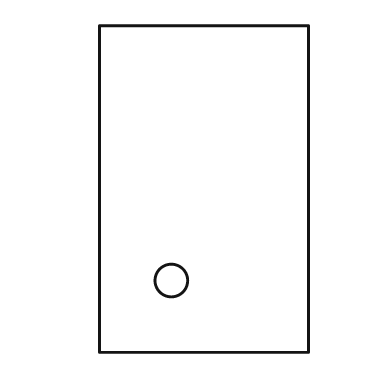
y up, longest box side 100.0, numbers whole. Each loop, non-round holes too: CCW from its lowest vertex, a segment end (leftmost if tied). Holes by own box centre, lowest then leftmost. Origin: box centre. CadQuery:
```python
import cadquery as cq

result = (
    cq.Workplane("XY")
    .moveTo(-32.0, -50.0)
    .lineTo(32.0, -50.0)
    .lineTo(32.0, 50.0)
    .lineTo(-32.0, 50.0)
    .close()
    .moveTo(-10.0, -28.0)
    .circle(5.0)
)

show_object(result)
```